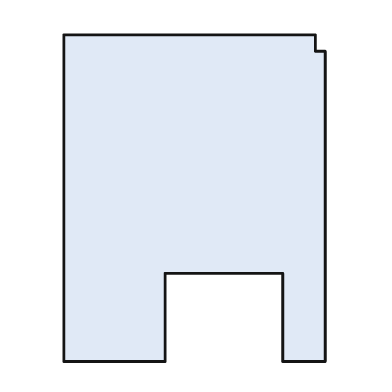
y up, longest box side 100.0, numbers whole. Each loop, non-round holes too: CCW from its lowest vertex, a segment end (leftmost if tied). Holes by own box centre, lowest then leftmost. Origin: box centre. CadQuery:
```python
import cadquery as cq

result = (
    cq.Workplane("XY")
    .moveTo(-40.0, -50.0)
    .lineTo(-9.0, -50.0)
    .lineTo(-9.0, -23.0)
    .lineTo(27.0, -23.0)
    .lineTo(27.0, -50.0)
    .lineTo(40.0, -50.0)
    .lineTo(40.0, 45.0)
    .lineTo(37.0, 45.0)
    .lineTo(37.0, 50.0)
    .lineTo(-40.0, 50.0)
    .close()
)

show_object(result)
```